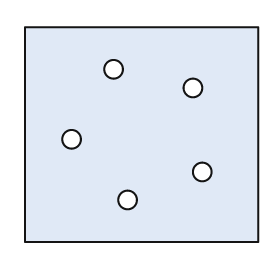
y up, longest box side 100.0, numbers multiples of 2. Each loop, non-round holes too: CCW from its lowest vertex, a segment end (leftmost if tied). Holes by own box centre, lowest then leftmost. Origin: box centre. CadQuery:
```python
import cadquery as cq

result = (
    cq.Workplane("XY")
    .moveTo(-50.0, -46.0)
    .lineTo(50.0, -46.0)
    .lineTo(50.0, 46.0)
    .lineTo(-50.0, 46.0)
    .close()
    .moveTo(-6.0, -28.0)
    .circle(4.0)
    .moveTo(26.0, -16.0)
    .circle(4.0)
    .moveTo(-30.0, -2.0)
    .circle(4.0)
    .moveTo(22.0, 20.0)
    .circle(4.0)
    .moveTo(-12.0, 28.0)
    .circle(4.0)
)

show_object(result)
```